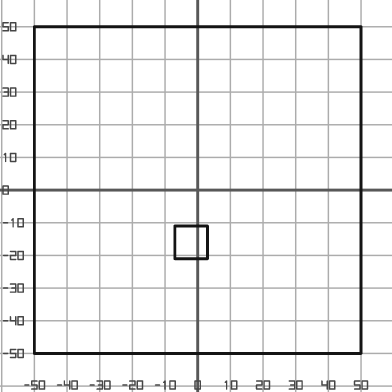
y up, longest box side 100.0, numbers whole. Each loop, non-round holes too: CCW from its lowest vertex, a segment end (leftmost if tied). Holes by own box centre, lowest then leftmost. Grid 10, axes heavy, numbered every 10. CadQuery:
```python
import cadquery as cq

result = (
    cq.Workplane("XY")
    .moveTo(-50.0, -50.0)
    .lineTo(50.0, -50.0)
    .lineTo(50.0, 50.0)
    .lineTo(-50.0, 50.0)
    .close()
    .moveTo(-7.0, -21.0)
    .lineTo(3.0, -21.0)
    .lineTo(3.0, -11.0)
    .lineTo(-7.0, -11.0)
    .close()
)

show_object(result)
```